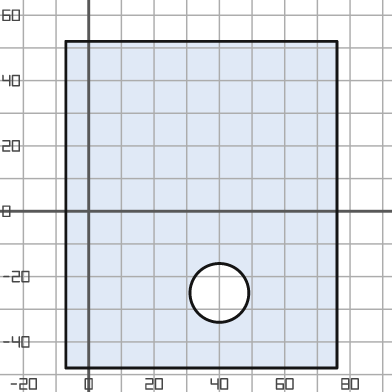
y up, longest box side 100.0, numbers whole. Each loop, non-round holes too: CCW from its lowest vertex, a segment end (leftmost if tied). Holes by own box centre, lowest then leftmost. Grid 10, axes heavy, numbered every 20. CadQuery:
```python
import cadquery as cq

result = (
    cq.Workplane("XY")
    .moveTo(-7.0, -48.0)
    .lineTo(76.0, -48.0)
    .lineTo(76.0, 52.0)
    .lineTo(-7.0, 52.0)
    .close()
    .moveTo(40.0, -25.0)
    .circle(9.0)
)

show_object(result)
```